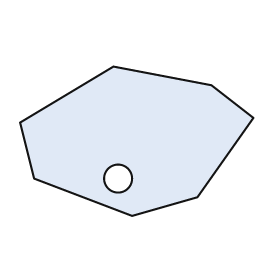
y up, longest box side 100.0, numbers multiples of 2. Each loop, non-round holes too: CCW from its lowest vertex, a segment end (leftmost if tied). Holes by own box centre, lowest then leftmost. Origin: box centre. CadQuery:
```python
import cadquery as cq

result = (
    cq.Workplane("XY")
    .moveTo(-2.0, -32.0)
    .lineTo(26.0, -24.0)
    .lineTo(50.0, 10.0)
    .lineTo(32.0, 24.0)
    .lineTo(-10.0, 32.0)
    .lineTo(-50.0, 8.0)
    .lineTo(-44.0, -16.0)
    .close()
    .moveTo(-8.0, -16.0)
    .circle(6.0)
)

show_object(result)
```